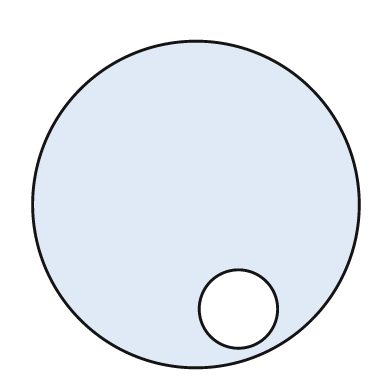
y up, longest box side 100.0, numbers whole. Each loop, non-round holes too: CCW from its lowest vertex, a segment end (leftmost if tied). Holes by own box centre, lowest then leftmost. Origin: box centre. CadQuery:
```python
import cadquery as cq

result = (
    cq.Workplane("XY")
    .moveTo(0.0, 0.0)
    .circle(50.0)
    .moveTo(13.0, -32.0)
    .circle(12.0)
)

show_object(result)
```